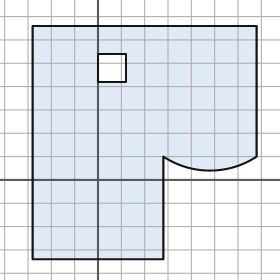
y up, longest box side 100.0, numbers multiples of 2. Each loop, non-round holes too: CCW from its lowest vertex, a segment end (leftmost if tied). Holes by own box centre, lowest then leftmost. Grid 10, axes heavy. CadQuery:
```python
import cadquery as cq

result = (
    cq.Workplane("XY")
    .moveTo(-28.0, -34.0)
    .lineTo(28.0, -34.0)
    .lineTo(28.0, 10.0)
    .threePointArc((48.0, 4.0), (68.0, 10.0))
    .lineTo(68.0, 66.0)
    .lineTo(-28.0, 66.0)
    .close()
    .moveTo(0.0, 42.0)
    .lineTo(12.0, 42.0)
    .lineTo(12.0, 54.0)
    .lineTo(0.0, 54.0)
    .close()
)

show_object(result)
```